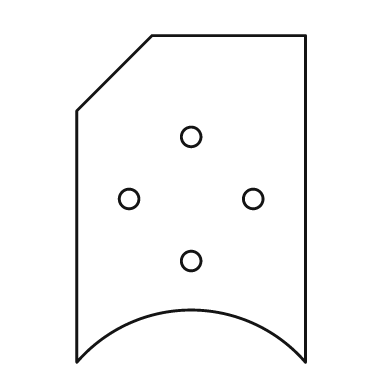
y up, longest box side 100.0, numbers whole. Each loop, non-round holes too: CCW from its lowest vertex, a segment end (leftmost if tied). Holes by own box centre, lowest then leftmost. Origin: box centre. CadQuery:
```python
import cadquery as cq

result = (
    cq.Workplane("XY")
    .moveTo(-35.0, -50.0)
    .threePointArc((0.0, -34.0), (35.0, -50.0))
    .lineTo(35.0, 50.0)
    .lineTo(-12.0, 50.0)
    .lineTo(-35.0, 27.0)
    .close()
    .moveTo(0.0, -19.0)
    .circle(3.0)
    .moveTo(-19.0, 0.0)
    .circle(3.0)
    .moveTo(19.0, 0.0)
    .circle(3.0)
    .moveTo(0.0, 19.0)
    .circle(3.0)
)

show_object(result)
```